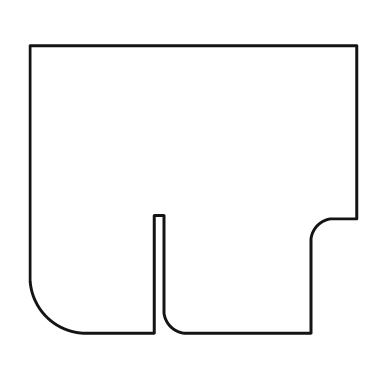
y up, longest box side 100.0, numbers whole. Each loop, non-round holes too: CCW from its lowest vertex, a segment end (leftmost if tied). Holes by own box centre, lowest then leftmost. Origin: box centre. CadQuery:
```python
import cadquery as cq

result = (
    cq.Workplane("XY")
    .moveTo(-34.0, -44.0)
    .lineTo(-12.0, -44.0)
    .lineTo(-12.0, -8.0)
    .lineTo(-9.0, -8.0)
    .lineTo(-9.0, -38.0)
    .threePointArc((-7.0, -42.0), (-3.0, -44.0))
    .lineTo(36.0, -44.0)
    .lineTo(36.0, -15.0)
    .threePointArc((38.0, -11.0), (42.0, -9.0))
    .lineTo(50.0, -9.0)
    .lineTo(50.0, 44.0)
    .lineTo(-50.0, 44.0)
    .lineTo(-50.0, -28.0)
    .threePointArc((-45.0, -39.0), (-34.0, -44.0))
    .close()
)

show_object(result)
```